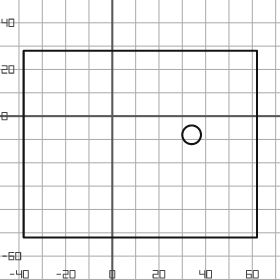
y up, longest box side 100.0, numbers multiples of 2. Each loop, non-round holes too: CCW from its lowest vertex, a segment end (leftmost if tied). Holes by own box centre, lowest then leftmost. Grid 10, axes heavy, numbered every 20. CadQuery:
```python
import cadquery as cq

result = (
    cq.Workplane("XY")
    .moveTo(-38.0, -52.0)
    .lineTo(62.0, -52.0)
    .lineTo(62.0, 28.0)
    .lineTo(-38.0, 28.0)
    .close()
    .moveTo(34.0, -8.0)
    .circle(4.0)
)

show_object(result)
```